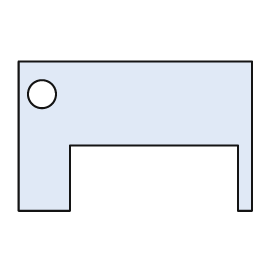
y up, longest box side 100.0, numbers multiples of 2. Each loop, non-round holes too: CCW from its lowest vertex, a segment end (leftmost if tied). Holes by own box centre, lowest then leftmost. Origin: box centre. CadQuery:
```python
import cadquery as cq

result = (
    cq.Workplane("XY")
    .moveTo(-50.0, -32.0)
    .lineTo(-28.0, -32.0)
    .lineTo(-28.0, -4.0)
    .lineTo(44.0, -4.0)
    .lineTo(44.0, -32.0)
    .lineTo(50.0, -32.0)
    .lineTo(50.0, 32.0)
    .lineTo(-50.0, 32.0)
    .close()
    .moveTo(-40.0, 18.0)
    .circle(6.0)
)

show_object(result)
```